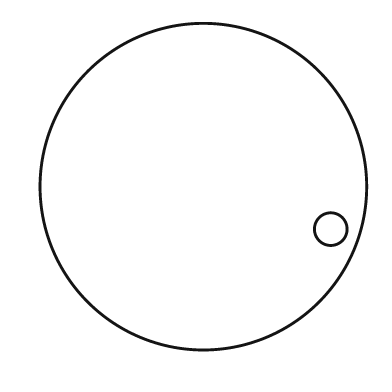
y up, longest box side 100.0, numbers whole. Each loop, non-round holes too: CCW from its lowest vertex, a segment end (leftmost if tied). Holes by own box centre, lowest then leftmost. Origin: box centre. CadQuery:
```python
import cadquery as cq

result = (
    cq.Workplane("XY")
    .moveTo(0.0, 0.0)
    .circle(50.0)
    .moveTo(39.0, -13.0)
    .circle(5.0)
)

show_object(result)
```